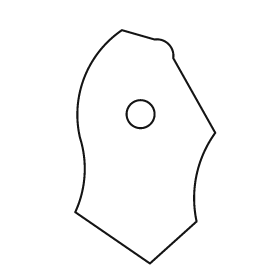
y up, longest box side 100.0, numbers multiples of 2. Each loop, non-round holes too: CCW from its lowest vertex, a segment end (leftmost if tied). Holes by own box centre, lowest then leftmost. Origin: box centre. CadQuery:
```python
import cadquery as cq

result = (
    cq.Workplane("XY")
    .moveTo(2.0, -50.0)
    .lineTo(22.0, -32.0)
    .threePointArc((22.0, -12.0), (30.0, 6.0))
    .lineTo(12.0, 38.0)
    .threePointArc((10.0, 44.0), (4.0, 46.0))
    .lineTo(-10.0, 50.0)
    .threePointArc((-26.0, 30.0), (-28.0, 4.0))
    .threePointArc((-26.0, -12.0), (-30.0, -28.0))
    .close()
    .moveTo(-2.0, 14.0)
    .circle(6.0)
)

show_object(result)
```